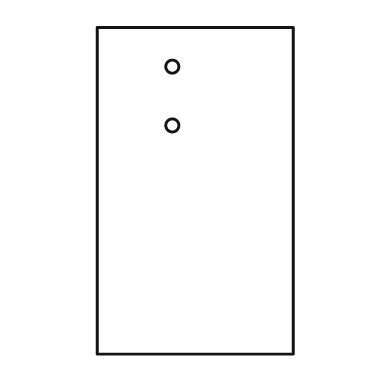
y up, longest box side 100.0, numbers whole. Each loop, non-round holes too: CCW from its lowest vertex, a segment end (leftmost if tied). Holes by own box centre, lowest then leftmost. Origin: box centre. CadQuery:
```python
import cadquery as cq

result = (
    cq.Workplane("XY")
    .moveTo(-30.0, -50.0)
    .lineTo(30.0, -50.0)
    .lineTo(30.0, 50.0)
    .lineTo(-30.0, 50.0)
    .close()
    .moveTo(-7.0, 20.0)
    .circle(2.0)
    .moveTo(-7.0, 38.0)
    .circle(2.0)
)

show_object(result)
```